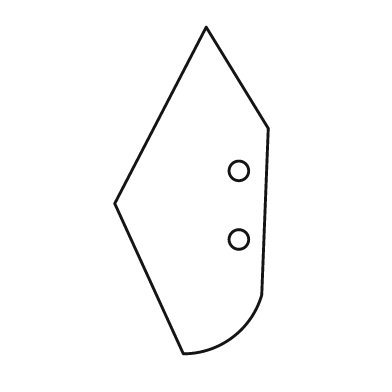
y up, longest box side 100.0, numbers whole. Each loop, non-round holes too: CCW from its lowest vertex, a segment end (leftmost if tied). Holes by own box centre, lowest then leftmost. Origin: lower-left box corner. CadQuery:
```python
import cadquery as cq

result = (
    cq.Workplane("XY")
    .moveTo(21.0, 0.0)
    .threePointArc((36.0, 5.0), (45.0, 18.0))
    .lineTo(47.0, 69.0)
    .lineTo(28.0, 100.0)
    .lineTo(0.0, 46.0)
    .close()
    .moveTo(38.0, 35.0)
    .circle(3.0)
    .moveTo(38.0, 56.0)
    .circle(3.0)
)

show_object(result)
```